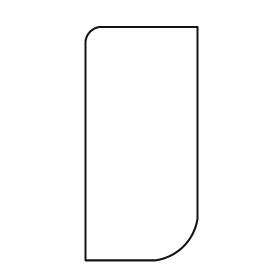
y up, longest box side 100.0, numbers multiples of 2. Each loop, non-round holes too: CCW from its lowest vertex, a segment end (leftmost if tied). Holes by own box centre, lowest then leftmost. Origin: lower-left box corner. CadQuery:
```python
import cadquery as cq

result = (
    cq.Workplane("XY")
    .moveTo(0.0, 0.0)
    .lineTo(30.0, 0.0)
    .threePointArc((42.0, 6.0), (48.0, 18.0))
    .lineTo(48.0, 100.0)
    .lineTo(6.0, 100.0)
    .threePointArc((2.0, 98.0), (0.0, 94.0))
    .close()
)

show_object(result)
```